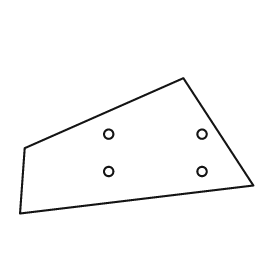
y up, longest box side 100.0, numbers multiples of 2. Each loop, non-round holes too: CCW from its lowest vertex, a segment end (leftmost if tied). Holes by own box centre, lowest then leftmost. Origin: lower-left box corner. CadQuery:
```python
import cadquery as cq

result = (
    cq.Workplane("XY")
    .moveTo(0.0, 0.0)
    .lineTo(100.0, 12.0)
    .lineTo(70.0, 58.0)
    .lineTo(2.0, 28.0)
    .close()
    .moveTo(38.0, 18.0)
    .circle(2.0)
    .moveTo(78.0, 18.0)
    .circle(2.0)
    .moveTo(38.0, 34.0)
    .circle(2.0)
    .moveTo(78.0, 34.0)
    .circle(2.0)
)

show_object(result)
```